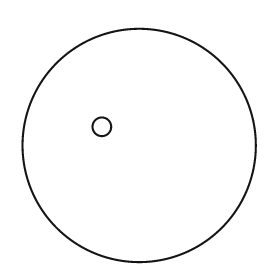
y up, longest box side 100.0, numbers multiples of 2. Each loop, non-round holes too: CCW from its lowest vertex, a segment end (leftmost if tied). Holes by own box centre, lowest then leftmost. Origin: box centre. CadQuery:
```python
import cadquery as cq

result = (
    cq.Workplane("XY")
    .moveTo(0.0, 0.0)
    .circle(50.0)
    .moveTo(-16.0, 8.0)
    .circle(4.0)
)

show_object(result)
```